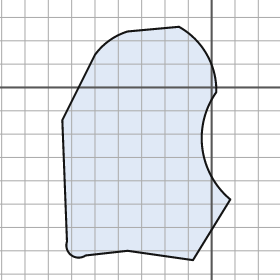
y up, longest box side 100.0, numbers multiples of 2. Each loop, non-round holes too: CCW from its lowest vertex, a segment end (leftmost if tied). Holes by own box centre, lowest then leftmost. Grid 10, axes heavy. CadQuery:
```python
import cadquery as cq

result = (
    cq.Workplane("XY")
    .moveTo(-8.0, -74.0)
    .lineTo(8.0, -48.0)
    .threePointArc((-4.0, -26.0), (2.0, -2.0))
    .threePointArc((-2.0, 14.0), (-14.0, 26.0))
    .lineTo(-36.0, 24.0)
    .threePointArc((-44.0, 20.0), (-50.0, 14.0))
    .lineTo(-64.0, -14.0)
    .lineTo(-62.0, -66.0)
    .threePointArc((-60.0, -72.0), (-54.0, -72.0))
    .lineTo(-36.0, -70.0)
    .close()
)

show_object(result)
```